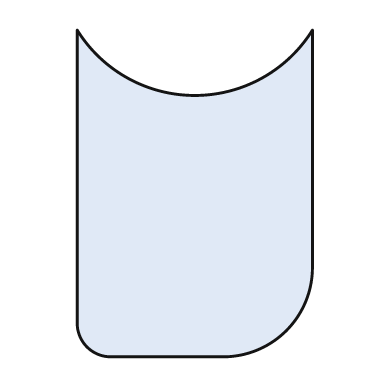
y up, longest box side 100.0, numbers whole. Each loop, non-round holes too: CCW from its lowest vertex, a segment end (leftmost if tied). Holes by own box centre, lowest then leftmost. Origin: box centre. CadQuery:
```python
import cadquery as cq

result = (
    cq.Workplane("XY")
    .moveTo(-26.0, -50.0)
    .lineTo(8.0, -50.0)
    .threePointArc((28.0, -42.0), (36.0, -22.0))
    .lineTo(36.0, 50.0)
    .threePointArc((0.0, 30.0), (-36.0, 50.0))
    .lineTo(-36.0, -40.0)
    .threePointArc((-33.0, -47.0), (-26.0, -50.0))
    .close()
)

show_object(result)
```